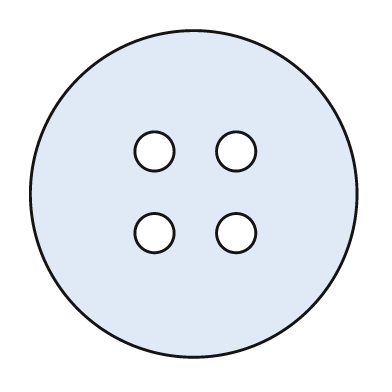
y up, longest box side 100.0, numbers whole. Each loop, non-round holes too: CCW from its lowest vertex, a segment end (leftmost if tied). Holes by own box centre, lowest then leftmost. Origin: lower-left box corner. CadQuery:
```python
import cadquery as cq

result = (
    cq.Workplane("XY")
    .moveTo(50.0, 50.0)
    .circle(50.0)
    .moveTo(38.0, 38.0)
    .circle(6.0)
    .moveTo(63.0, 38.0)
    .circle(6.0)
    .moveTo(38.0, 63.0)
    .circle(6.0)
    .moveTo(63.0, 63.0)
    .circle(6.0)
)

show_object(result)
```